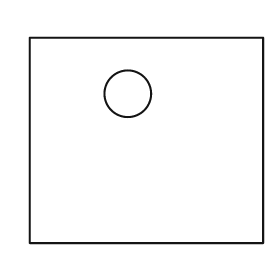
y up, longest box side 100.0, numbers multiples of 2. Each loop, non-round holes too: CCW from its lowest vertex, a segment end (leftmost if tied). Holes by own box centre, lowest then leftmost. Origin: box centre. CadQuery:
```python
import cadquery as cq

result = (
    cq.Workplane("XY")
    .moveTo(-50.0, -44.0)
    .lineTo(50.0, -44.0)
    .lineTo(50.0, 44.0)
    .lineTo(-50.0, 44.0)
    .close()
    .moveTo(-8.0, 20.0)
    .circle(10.0)
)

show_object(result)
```